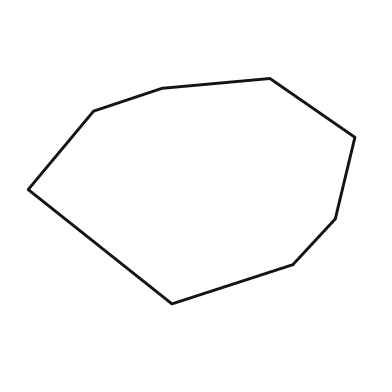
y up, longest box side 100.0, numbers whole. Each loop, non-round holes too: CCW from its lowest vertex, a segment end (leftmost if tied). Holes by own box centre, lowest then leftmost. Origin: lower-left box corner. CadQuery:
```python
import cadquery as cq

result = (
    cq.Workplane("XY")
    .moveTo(44.0, 0.0)
    .lineTo(81.0, 12.0)
    .lineTo(94.0, 26.0)
    .lineTo(100.0, 51.0)
    .lineTo(74.0, 69.0)
    .lineTo(41.0, 66.0)
    .lineTo(20.0, 59.0)
    .lineTo(0.0, 35.0)
    .close()
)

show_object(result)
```